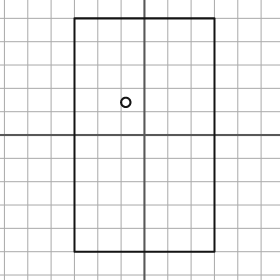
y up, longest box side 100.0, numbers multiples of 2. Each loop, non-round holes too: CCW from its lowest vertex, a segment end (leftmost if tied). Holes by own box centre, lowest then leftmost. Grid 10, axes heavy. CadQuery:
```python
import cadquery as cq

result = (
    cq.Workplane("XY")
    .moveTo(-30.0, -50.0)
    .lineTo(30.0, -50.0)
    .lineTo(30.0, 50.0)
    .lineTo(-30.0, 50.0)
    .close()
    .moveTo(-8.0, 14.0)
    .circle(2.0)
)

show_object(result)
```